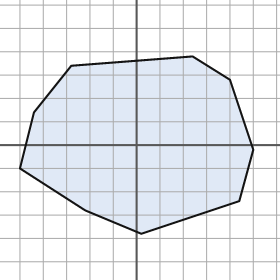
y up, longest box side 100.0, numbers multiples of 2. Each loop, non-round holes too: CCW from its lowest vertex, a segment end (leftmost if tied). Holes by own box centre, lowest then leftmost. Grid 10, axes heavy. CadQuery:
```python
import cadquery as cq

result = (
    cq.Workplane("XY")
    .moveTo(2.0, -38.0)
    .lineTo(44.0, -24.0)
    .lineTo(50.0, -2.0)
    .lineTo(40.0, 28.0)
    .lineTo(24.0, 38.0)
    .lineTo(-28.0, 34.0)
    .lineTo(-44.0, 14.0)
    .lineTo(-50.0, -10.0)
    .lineTo(-22.0, -28.0)
    .close()
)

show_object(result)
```